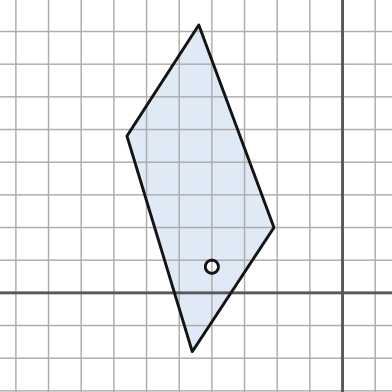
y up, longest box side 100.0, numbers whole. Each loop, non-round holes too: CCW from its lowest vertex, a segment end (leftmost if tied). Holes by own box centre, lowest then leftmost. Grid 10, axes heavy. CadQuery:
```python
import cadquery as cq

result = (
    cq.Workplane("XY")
    .moveTo(-46.0, -18.0)
    .lineTo(-21.0, 20.0)
    .lineTo(-44.0, 82.0)
    .lineTo(-66.0, 48.0)
    .close()
    .moveTo(-40.0, 8.0)
    .circle(2.0)
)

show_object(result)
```